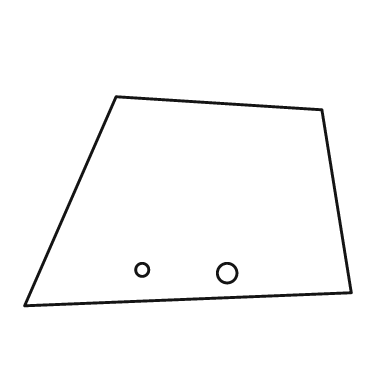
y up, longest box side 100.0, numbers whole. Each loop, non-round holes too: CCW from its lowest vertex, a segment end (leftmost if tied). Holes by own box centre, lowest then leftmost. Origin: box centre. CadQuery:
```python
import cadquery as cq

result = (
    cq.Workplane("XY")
    .moveTo(-50.0, -32.0)
    .lineTo(50.0, -28.0)
    .lineTo(41.0, 28.0)
    .lineTo(-22.0, 32.0)
    .close()
    .moveTo(12.0, -22.0)
    .circle(3.0)
    .moveTo(-14.0, -21.0)
    .circle(2.0)
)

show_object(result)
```